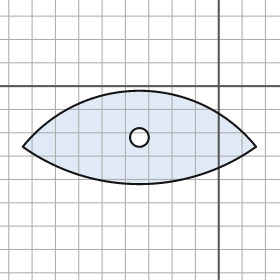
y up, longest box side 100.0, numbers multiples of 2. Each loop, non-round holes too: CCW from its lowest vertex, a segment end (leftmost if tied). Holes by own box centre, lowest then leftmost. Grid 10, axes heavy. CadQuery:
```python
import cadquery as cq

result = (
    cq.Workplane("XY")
    .moveTo(-84.0, -26.0)
    .threePointArc((-34.0, -42.0), (16.0, -26.0))
    .threePointArc((-34.0, -2.0), (-84.0, -26.0))
    .close()
    .moveTo(-34.0, -22.0)
    .circle(4.0)
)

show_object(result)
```